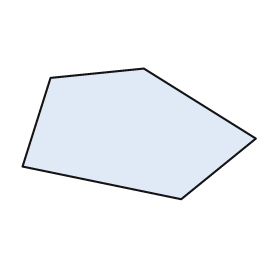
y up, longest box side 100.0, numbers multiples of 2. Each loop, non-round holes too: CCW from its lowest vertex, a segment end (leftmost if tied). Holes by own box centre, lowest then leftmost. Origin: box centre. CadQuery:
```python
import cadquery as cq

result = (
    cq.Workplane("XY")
    .moveTo(18.0, -28.0)
    .lineTo(50.0, -2.0)
    .lineTo(2.0, 28.0)
    .lineTo(-38.0, 24.0)
    .lineTo(-50.0, -14.0)
    .close()
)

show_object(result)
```